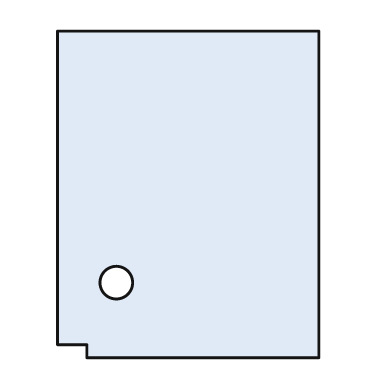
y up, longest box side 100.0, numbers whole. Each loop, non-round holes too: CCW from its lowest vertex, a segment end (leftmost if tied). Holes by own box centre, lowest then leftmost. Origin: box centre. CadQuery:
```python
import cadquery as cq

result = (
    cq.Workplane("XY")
    .moveTo(-31.0, -50.0)
    .lineTo(40.0, -50.0)
    .lineTo(40.0, 50.0)
    .lineTo(-40.0, 50.0)
    .lineTo(-40.0, -46.0)
    .lineTo(-31.0, -46.0)
    .close()
    .moveTo(-22.0, -27.0)
    .circle(5.0)
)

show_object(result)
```